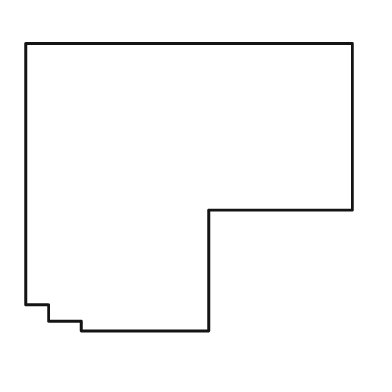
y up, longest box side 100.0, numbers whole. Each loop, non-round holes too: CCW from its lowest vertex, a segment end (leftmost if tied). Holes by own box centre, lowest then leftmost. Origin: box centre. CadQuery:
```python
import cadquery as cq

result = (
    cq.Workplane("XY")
    .moveTo(-33.0, -44.0)
    .lineTo(6.0, -44.0)
    .lineTo(6.0, -7.0)
    .lineTo(50.0, -7.0)
    .lineTo(50.0, 44.0)
    .lineTo(-50.0, 44.0)
    .lineTo(-50.0, -36.0)
    .lineTo(-43.0, -36.0)
    .lineTo(-43.0, -41.0)
    .lineTo(-33.0, -41.0)
    .close()
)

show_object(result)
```